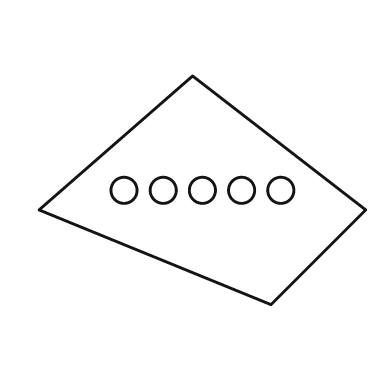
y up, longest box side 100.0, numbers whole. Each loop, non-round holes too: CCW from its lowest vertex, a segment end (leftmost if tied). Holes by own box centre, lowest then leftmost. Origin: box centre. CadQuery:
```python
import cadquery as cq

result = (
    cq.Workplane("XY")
    .moveTo(21.0, -35.0)
    .lineTo(50.0, -6.0)
    .lineTo(-3.0, 35.0)
    .lineTo(-50.0, -6.0)
    .close()
    .moveTo(-24.0, 0.0)
    .circle(4.0)
    .moveTo(-12.0, 0.0)
    .circle(4.0)
    .moveTo(0.0, 0.0)
    .circle(4.0)
    .moveTo(12.0, 0.0)
    .circle(4.0)
    .moveTo(24.0, 0.0)
    .circle(4.0)
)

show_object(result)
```